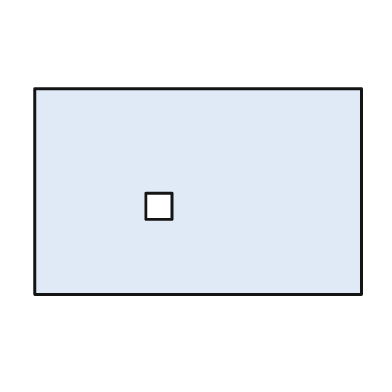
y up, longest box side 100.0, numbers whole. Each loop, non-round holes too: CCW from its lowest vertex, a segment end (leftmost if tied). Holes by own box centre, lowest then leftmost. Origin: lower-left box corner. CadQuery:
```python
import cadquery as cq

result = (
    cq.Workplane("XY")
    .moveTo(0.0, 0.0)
    .lineTo(100.0, 0.0)
    .lineTo(100.0, 63.0)
    .lineTo(0.0, 63.0)
    .close()
    .moveTo(34.0, 23.0)
    .lineTo(42.0, 23.0)
    .lineTo(42.0, 31.0)
    .lineTo(34.0, 31.0)
    .close()
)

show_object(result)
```